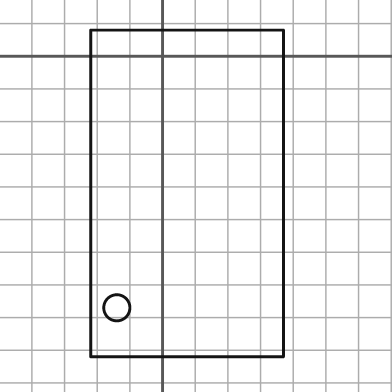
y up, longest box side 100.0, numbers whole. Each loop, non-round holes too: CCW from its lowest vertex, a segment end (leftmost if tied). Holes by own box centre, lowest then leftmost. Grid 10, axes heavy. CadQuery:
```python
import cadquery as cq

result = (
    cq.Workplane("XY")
    .moveTo(-22.0, -92.0)
    .lineTo(37.0, -92.0)
    .lineTo(37.0, 8.0)
    .lineTo(-22.0, 8.0)
    .close()
    .moveTo(-14.0, -77.0)
    .circle(4.0)
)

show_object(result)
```